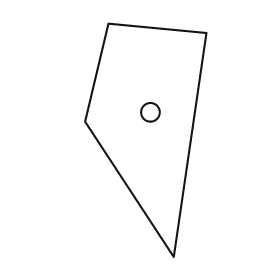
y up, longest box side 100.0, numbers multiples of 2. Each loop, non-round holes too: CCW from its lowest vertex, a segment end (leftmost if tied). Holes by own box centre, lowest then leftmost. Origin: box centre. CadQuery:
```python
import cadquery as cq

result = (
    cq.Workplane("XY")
    .moveTo(12.0, -50.0)
    .lineTo(26.0, 46.0)
    .lineTo(-16.0, 50.0)
    .lineTo(-26.0, 8.0)
    .close()
    .moveTo(2.0, 12.0)
    .circle(4.0)
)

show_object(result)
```